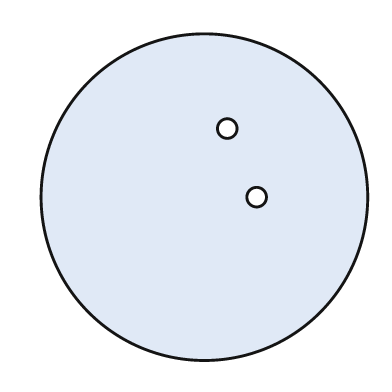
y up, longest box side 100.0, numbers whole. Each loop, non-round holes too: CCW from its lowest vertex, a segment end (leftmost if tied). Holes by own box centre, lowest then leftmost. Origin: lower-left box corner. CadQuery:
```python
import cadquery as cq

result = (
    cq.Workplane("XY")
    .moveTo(50.0, 50.0)
    .circle(50.0)
    .moveTo(66.0, 50.0)
    .circle(3.0)
    .moveTo(57.0, 71.0)
    .circle(3.0)
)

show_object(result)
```